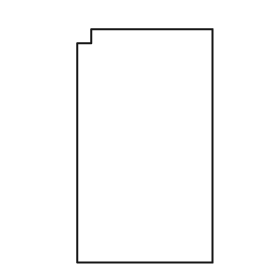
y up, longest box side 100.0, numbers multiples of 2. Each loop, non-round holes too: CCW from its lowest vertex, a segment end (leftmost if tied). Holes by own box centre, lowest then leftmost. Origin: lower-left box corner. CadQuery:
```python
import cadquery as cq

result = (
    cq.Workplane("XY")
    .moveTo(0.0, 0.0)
    .lineTo(58.0, 0.0)
    .lineTo(58.0, 100.0)
    .lineTo(6.0, 100.0)
    .lineTo(6.0, 94.0)
    .lineTo(0.0, 94.0)
    .close()
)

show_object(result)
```